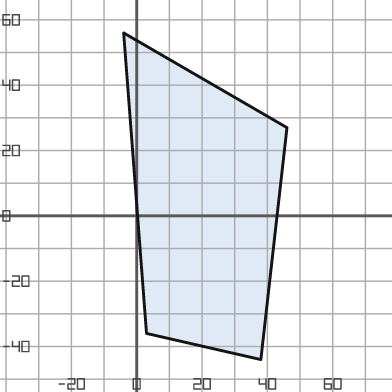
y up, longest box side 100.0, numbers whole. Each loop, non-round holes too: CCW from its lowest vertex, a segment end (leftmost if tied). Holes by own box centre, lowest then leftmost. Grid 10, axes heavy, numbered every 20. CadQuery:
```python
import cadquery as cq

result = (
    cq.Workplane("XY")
    .moveTo(38.0, -44.0)
    .lineTo(46.0, 27.0)
    .lineTo(-4.0, 56.0)
    .lineTo(3.0, -36.0)
    .close()
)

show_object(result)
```